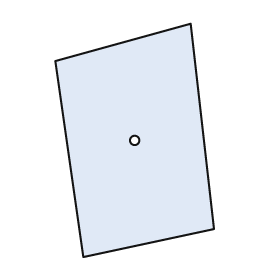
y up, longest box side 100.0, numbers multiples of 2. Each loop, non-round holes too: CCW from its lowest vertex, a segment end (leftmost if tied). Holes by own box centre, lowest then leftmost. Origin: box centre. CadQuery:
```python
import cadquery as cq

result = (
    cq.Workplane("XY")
    .moveTo(-22.0, -50.0)
    .lineTo(34.0, -38.0)
    .lineTo(24.0, 50.0)
    .lineTo(-34.0, 34.0)
    .close()
    .moveTo(0.0, 0.0)
    .circle(2.0)
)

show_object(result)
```